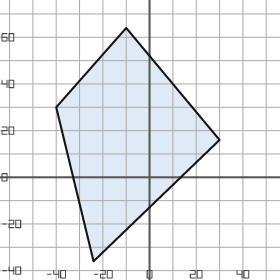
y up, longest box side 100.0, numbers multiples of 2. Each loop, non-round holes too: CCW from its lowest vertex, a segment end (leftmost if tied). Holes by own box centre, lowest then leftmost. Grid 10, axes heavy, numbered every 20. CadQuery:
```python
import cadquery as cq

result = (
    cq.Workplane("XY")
    .moveTo(-24.0, -36.0)
    .lineTo(30.0, 16.0)
    .lineTo(-10.0, 64.0)
    .lineTo(-40.0, 30.0)
    .close()
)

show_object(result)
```